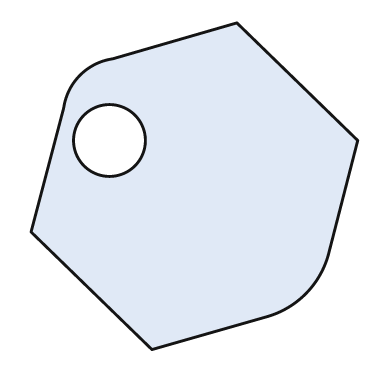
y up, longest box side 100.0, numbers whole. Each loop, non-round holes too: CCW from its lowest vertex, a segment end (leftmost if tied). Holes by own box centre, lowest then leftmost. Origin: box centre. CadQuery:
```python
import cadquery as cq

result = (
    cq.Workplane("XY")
    .moveTo(-13.0, -50.0)
    .lineTo(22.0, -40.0)
    .threePointArc((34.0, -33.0), (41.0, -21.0))
    .lineTo(50.0, 14.0)
    .lineTo(13.0, 50.0)
    .lineTo(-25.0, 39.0)
    .threePointArc((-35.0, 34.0), (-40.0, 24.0))
    .lineTo(-50.0, -14.0)
    .close()
    .moveTo(-26.0, 14.0)
    .circle(11.0)
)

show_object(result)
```